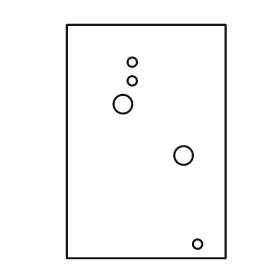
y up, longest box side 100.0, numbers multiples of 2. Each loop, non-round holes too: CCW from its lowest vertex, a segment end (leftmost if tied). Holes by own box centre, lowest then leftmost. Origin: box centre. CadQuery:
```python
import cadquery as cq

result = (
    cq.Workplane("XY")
    .moveTo(-34.0, -50.0)
    .lineTo(34.0, -50.0)
    .lineTo(34.0, 50.0)
    .lineTo(-34.0, 50.0)
    .close()
    .moveTo(22.0, -44.0)
    .circle(2.0)
    .moveTo(16.0, -6.0)
    .circle(4.0)
    .moveTo(-10.0, 16.0)
    .circle(4.0)
    .moveTo(-6.0, 26.0)
    .circle(2.0)
    .moveTo(-6.0, 34.0)
    .circle(2.0)
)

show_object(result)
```